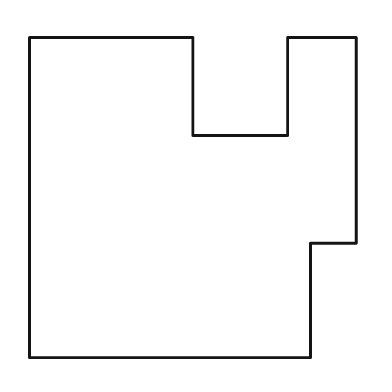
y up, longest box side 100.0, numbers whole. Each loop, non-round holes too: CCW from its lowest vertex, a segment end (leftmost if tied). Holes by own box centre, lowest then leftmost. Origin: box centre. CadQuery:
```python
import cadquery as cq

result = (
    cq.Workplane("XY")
    .moveTo(-50.0, -49.0)
    .lineTo(36.0, -49.0)
    .lineTo(36.0, -14.0)
    .lineTo(50.0, -14.0)
    .lineTo(50.0, 49.0)
    .lineTo(29.0, 49.0)
    .lineTo(29.0, 19.0)
    .lineTo(0.0, 19.0)
    .lineTo(0.0, 49.0)
    .lineTo(-50.0, 49.0)
    .close()
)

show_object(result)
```